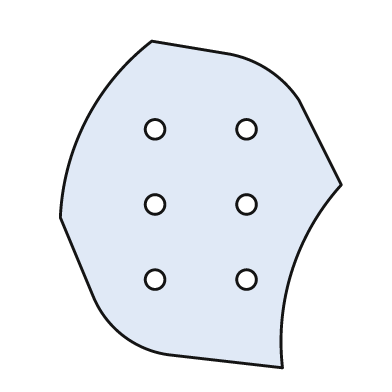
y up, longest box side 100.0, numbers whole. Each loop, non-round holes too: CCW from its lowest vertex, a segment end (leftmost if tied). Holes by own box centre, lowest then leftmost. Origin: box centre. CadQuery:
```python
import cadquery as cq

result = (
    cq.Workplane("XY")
    .moveTo(25.0, -50.0)
    .threePointArc((28.0, -20.0), (43.0, 6.0))
    .lineTo(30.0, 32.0)
    .threePointArc((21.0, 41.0), (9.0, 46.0))
    .lineTo(-15.0, 50.0)
    .threePointArc((-35.0, 26.0), (-43.0, -4.0))
    .lineTo(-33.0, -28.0)
    .threePointArc((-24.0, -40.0), (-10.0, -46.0))
    .close()
    .moveTo(-14.0, -23.0)
    .circle(3.0)
    .moveTo(14.0, -23.0)
    .circle(3.0)
    .moveTo(-14.0, 0.0)
    .circle(3.0)
    .moveTo(14.0, 0.0)
    .circle(3.0)
    .moveTo(-14.0, 23.0)
    .circle(3.0)
    .moveTo(14.0, 23.0)
    .circle(3.0)
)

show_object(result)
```